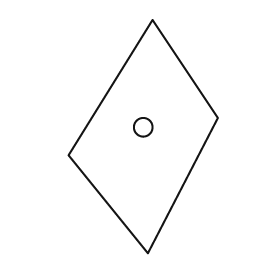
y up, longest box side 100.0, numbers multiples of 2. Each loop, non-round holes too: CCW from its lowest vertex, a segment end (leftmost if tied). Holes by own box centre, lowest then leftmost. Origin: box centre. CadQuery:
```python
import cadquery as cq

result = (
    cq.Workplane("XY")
    .moveTo(2.0, -50.0)
    .lineTo(32.0, 8.0)
    .lineTo(4.0, 50.0)
    .lineTo(-32.0, -8.0)
    .close()
    .moveTo(0.0, 4.0)
    .circle(4.0)
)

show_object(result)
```